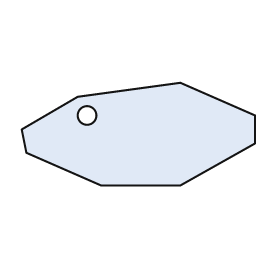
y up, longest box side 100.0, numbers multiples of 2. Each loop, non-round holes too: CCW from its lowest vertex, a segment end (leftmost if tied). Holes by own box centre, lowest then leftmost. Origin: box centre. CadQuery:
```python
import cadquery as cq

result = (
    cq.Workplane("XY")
    .moveTo(-16.0, -22.0)
    .lineTo(18.0, -22.0)
    .lineTo(50.0, -4.0)
    .lineTo(50.0, 8.0)
    .lineTo(18.0, 22.0)
    .lineTo(-26.0, 16.0)
    .lineTo(-50.0, 2.0)
    .lineTo(-48.0, -8.0)
    .close()
    .moveTo(-22.0, 8.0)
    .circle(4.0)
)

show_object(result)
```